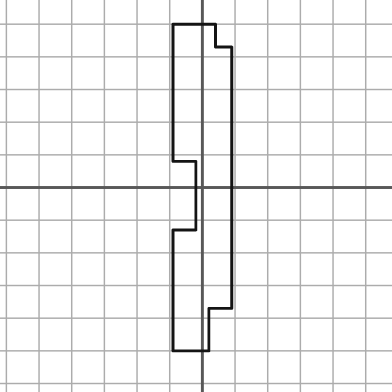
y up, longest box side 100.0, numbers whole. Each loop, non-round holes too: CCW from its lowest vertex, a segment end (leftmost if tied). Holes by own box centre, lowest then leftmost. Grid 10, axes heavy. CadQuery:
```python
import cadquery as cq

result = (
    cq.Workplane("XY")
    .moveTo(-9.0, -50.0)
    .lineTo(2.0, -50.0)
    .lineTo(2.0, -37.0)
    .lineTo(9.0, -37.0)
    .lineTo(9.0, 43.0)
    .lineTo(4.0, 43.0)
    .lineTo(4.0, 50.0)
    .lineTo(-9.0, 50.0)
    .lineTo(-9.0, 8.0)
    .lineTo(-2.0, 8.0)
    .lineTo(-2.0, -13.0)
    .lineTo(-9.0, -13.0)
    .close()
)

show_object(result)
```